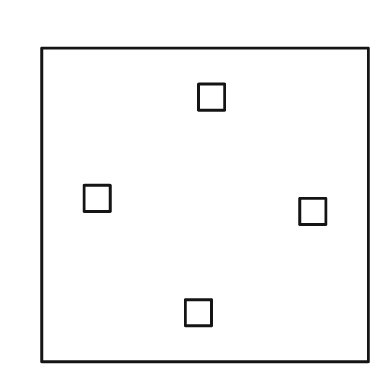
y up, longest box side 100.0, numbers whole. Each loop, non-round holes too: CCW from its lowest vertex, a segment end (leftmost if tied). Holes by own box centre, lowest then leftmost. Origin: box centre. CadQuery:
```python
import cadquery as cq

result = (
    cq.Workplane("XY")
    .moveTo(-50.0, -48.0)
    .lineTo(50.0, -48.0)
    .lineTo(50.0, 48.0)
    .lineTo(-50.0, 48.0)
    .close()
    .moveTo(-6.0, -37.0)
    .lineTo(2.0, -37.0)
    .lineTo(2.0, -29.0)
    .lineTo(-6.0, -29.0)
    .close()
    .moveTo(29.0, -6.0)
    .lineTo(37.0, -6.0)
    .lineTo(37.0, 2.0)
    .lineTo(29.0, 2.0)
    .close()
    .moveTo(-37.0, -2.0)
    .lineTo(-29.0, -2.0)
    .lineTo(-29.0, 6.0)
    .lineTo(-37.0, 6.0)
    .close()
    .moveTo(-2.0, 29.0)
    .lineTo(6.0, 29.0)
    .lineTo(6.0, 37.0)
    .lineTo(-2.0, 37.0)
    .close()
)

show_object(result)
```